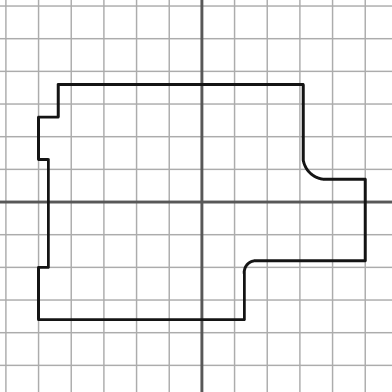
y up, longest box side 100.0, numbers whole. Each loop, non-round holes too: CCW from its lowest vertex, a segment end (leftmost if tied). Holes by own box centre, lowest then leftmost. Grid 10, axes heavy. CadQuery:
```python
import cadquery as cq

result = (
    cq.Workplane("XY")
    .moveTo(-50.0, -36.0)
    .lineTo(13.0, -36.0)
    .lineTo(13.0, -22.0)
    .threePointArc((14.0, -19.0), (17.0, -18.0))
    .lineTo(50.0, -18.0)
    .lineTo(50.0, 7.0)
    .lineTo(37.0, 7.0)
    .threePointArc((33.0, 9.0), (31.0, 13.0))
    .lineTo(31.0, 36.0)
    .lineTo(-44.0, 36.0)
    .lineTo(-44.0, 26.0)
    .lineTo(-50.0, 26.0)
    .lineTo(-50.0, 13.0)
    .lineTo(-47.0, 13.0)
    .lineTo(-47.0, -20.0)
    .lineTo(-50.0, -20.0)
    .close()
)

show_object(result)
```